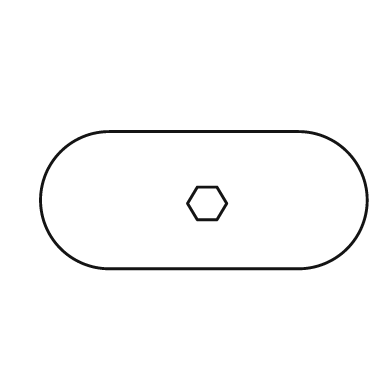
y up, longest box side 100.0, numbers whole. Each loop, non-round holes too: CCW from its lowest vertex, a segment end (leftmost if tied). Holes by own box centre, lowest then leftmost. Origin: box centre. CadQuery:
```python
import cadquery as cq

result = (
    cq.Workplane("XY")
    .moveTo(-29.0, -21.0)
    .lineTo(29.0, -21.0)
    .threePointArc((50.0, 0.0), (29.0, 21.0))
    .lineTo(-29.0, 21.0)
    .threePointArc((-50.0, 0.0), (-29.0, -21.0))
    .close()
    .moveTo(-2.0, -6.0)
    .lineTo(4.0, -6.0)
    .lineTo(7.0, -1.0)
    .lineTo(4.0, 4.0)
    .lineTo(-2.0, 4.0)
    .lineTo(-5.0, -1.0)
    .close()
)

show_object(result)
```